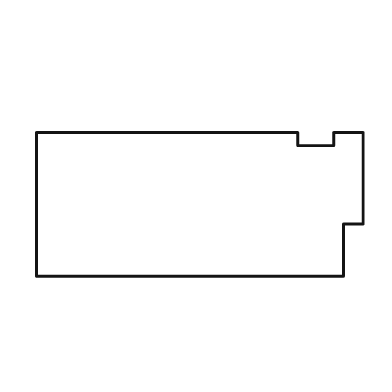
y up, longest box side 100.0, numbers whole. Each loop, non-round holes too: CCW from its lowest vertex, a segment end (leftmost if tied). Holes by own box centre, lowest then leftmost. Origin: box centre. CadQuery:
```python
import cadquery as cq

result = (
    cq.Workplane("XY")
    .moveTo(-50.0, -22.0)
    .lineTo(44.0, -22.0)
    .lineTo(44.0, -6.0)
    .lineTo(50.0, -6.0)
    .lineTo(50.0, 22.0)
    .lineTo(41.0, 22.0)
    .lineTo(41.0, 18.0)
    .lineTo(30.0, 18.0)
    .lineTo(30.0, 22.0)
    .lineTo(-50.0, 22.0)
    .close()
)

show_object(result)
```